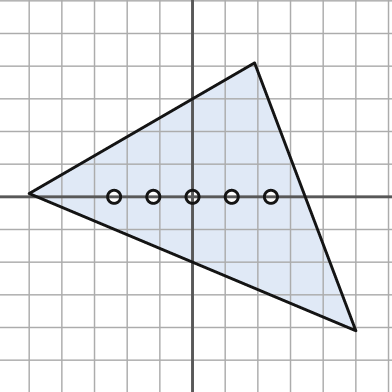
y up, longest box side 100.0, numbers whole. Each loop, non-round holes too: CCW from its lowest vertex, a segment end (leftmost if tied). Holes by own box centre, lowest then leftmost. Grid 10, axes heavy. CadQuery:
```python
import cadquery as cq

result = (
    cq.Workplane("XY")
    .moveTo(50.0, -41.0)
    .lineTo(19.0, 41.0)
    .lineTo(-50.0, 1.0)
    .close()
    .moveTo(-24.0, 0.0)
    .circle(2.0)
    .moveTo(-12.0, 0.0)
    .circle(2.0)
    .moveTo(0.0, 0.0)
    .circle(2.0)
    .moveTo(12.0, 0.0)
    .circle(2.0)
    .moveTo(24.0, 0.0)
    .circle(2.0)
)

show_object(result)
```